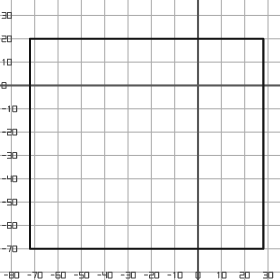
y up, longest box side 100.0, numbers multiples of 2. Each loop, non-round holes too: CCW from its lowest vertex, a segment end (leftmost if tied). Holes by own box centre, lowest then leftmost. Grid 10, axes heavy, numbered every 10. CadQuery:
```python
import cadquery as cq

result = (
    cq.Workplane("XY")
    .moveTo(-72.0, -70.0)
    .lineTo(28.0, -70.0)
    .lineTo(28.0, 20.0)
    .lineTo(-72.0, 20.0)
    .close()
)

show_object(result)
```